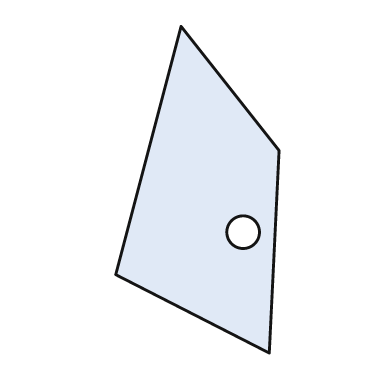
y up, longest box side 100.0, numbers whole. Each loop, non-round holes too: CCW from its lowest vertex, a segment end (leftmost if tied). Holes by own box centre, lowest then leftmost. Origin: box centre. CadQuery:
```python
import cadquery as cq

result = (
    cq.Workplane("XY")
    .moveTo(22.0, -50.0)
    .lineTo(25.0, 12.0)
    .lineTo(-5.0, 50.0)
    .lineTo(-25.0, -26.0)
    .close()
    .moveTo(14.0, -13.0)
    .circle(5.0)
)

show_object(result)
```